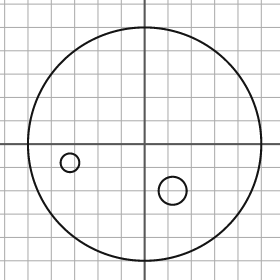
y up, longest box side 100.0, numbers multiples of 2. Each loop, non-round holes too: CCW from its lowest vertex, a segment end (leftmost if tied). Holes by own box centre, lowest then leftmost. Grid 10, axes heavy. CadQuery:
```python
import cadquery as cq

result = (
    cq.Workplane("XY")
    .moveTo(0.0, 0.0)
    .circle(50.0)
    .moveTo(12.0, -20.0)
    .circle(6.0)
    .moveTo(-32.0, -8.0)
    .circle(4.0)
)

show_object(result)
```